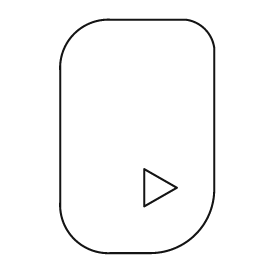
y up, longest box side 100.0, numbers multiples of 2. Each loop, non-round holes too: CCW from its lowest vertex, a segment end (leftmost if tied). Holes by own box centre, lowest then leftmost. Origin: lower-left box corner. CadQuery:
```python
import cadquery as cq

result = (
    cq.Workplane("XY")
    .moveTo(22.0, 0.0)
    .lineTo(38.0, 0.0)
    .threePointArc((58.0, 8.0), (66.0, 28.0))
    .lineTo(66.0, 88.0)
    .threePointArc((62.0, 96.0), (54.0, 100.0))
    .lineTo(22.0, 100.0)
    .threePointArc((6.0, 94.0), (0.0, 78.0))
    .lineTo(0.0, 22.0)
    .threePointArc((6.0, 6.0), (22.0, 0.0))
    .close()
    .moveTo(36.0, 20.0)
    .lineTo(50.0, 28.0)
    .lineTo(36.0, 36.0)
    .close()
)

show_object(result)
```